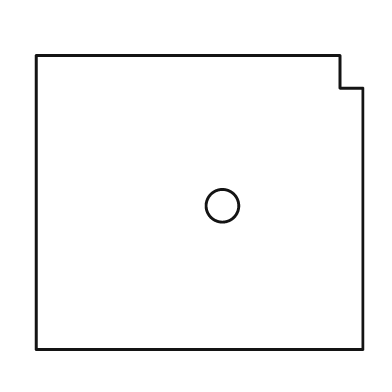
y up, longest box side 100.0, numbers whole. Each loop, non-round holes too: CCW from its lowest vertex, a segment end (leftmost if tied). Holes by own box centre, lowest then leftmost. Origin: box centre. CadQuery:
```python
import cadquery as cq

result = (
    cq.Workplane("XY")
    .moveTo(-50.0, -45.0)
    .lineTo(50.0, -45.0)
    .lineTo(50.0, 35.0)
    .lineTo(43.0, 35.0)
    .lineTo(43.0, 45.0)
    .lineTo(-50.0, 45.0)
    .close()
    .moveTo(7.0, -1.0)
    .circle(5.0)
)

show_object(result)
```